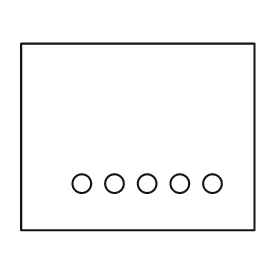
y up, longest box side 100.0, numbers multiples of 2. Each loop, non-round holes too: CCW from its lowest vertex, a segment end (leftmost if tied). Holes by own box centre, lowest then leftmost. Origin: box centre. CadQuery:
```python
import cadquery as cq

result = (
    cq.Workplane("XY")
    .moveTo(-50.0, -40.0)
    .lineTo(50.0, -40.0)
    .lineTo(50.0, 40.0)
    .lineTo(-50.0, 40.0)
    .close()
    .moveTo(-24.0, -20.0)
    .circle(4.0)
    .moveTo(-10.0, -20.0)
    .circle(4.0)
    .moveTo(4.0, -20.0)
    .circle(4.0)
    .moveTo(18.0, -20.0)
    .circle(4.0)
    .moveTo(32.0, -20.0)
    .circle(4.0)
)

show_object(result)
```